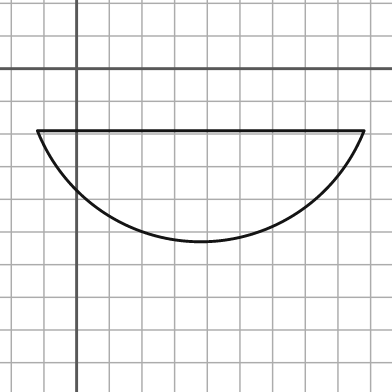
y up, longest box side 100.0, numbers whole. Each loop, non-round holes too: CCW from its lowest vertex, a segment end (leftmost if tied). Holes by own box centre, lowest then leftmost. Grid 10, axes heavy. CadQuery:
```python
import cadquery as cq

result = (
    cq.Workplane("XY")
    .moveTo(-12.0, -19.0)
    .threePointArc((38.0, -53.0), (88.0, -19.0))
    .close()
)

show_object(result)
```